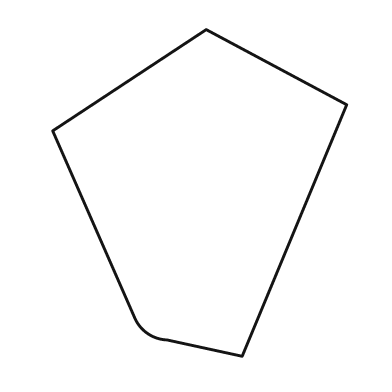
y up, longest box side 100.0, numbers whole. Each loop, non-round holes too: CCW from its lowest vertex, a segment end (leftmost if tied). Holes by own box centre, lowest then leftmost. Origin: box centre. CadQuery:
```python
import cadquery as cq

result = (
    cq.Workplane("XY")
    .moveTo(13.0, -50.0)
    .lineTo(45.0, 27.0)
    .lineTo(2.0, 50.0)
    .lineTo(-45.0, 19.0)
    .lineTo(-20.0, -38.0)
    .threePointArc((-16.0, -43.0), (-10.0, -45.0))
    .close()
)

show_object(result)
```